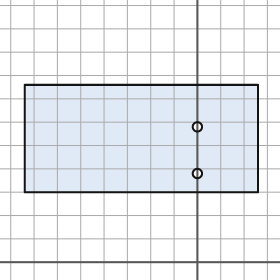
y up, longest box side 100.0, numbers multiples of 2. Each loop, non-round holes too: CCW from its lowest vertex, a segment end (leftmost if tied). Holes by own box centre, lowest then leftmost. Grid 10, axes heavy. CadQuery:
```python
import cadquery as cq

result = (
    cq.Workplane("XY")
    .moveTo(-74.0, 30.0)
    .lineTo(26.0, 30.0)
    .lineTo(26.0, 76.0)
    .lineTo(-74.0, 76.0)
    .close()
    .moveTo(0.0, 38.0)
    .circle(2.0)
    .moveTo(0.0, 58.0)
    .circle(2.0)
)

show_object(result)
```